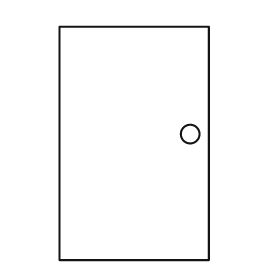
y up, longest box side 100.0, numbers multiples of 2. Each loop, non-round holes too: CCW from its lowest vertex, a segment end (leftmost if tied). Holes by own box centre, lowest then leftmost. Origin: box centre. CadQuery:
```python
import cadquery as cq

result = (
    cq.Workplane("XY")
    .moveTo(-32.0, -50.0)
    .lineTo(32.0, -50.0)
    .lineTo(32.0, 50.0)
    .lineTo(-32.0, 50.0)
    .close()
    .moveTo(24.0, 4.0)
    .circle(4.0)
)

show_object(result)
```